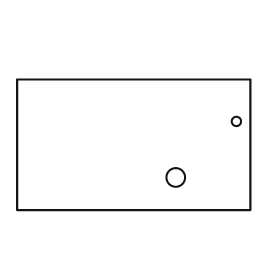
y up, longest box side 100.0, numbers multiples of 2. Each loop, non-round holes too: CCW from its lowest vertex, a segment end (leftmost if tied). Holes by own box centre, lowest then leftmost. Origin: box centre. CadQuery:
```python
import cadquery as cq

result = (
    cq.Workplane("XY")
    .moveTo(-50.0, -28.0)
    .lineTo(50.0, -28.0)
    .lineTo(50.0, 28.0)
    .lineTo(-50.0, 28.0)
    .close()
    .moveTo(18.0, -14.0)
    .circle(4.0)
    .moveTo(44.0, 10.0)
    .circle(2.0)
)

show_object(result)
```